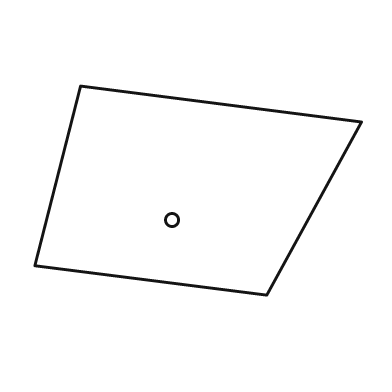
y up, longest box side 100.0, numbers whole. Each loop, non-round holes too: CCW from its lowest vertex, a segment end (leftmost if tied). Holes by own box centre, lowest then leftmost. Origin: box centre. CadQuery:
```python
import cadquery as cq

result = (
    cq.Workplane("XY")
    .moveTo(21.0, -32.0)
    .lineTo(50.0, 21.0)
    .lineTo(-36.0, 32.0)
    .lineTo(-50.0, -23.0)
    .close()
    .moveTo(-8.0, -9.0)
    .circle(2.0)
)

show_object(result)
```